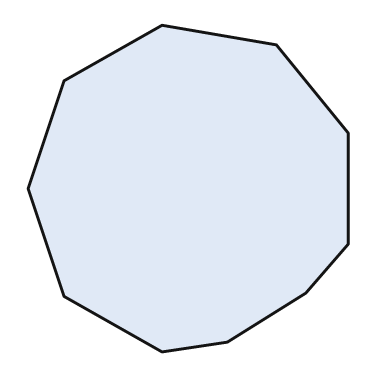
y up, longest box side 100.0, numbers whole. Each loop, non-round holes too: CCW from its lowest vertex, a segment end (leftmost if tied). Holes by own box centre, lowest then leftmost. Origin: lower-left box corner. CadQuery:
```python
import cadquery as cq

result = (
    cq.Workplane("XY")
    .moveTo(41.0, 0.0)
    .lineTo(61.0, 3.0)
    .lineTo(85.0, 18.0)
    .lineTo(98.0, 33.0)
    .lineTo(98.0, 67.0)
    .lineTo(76.0, 94.0)
    .lineTo(41.0, 100.0)
    .lineTo(11.0, 83.0)
    .lineTo(0.0, 50.0)
    .lineTo(11.0, 17.0)
    .close()
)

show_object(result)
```